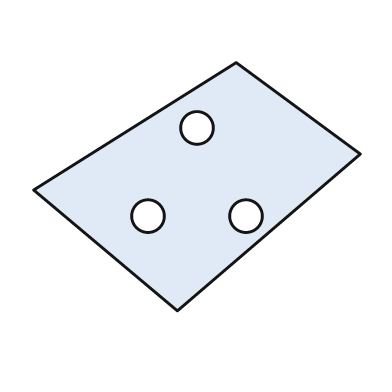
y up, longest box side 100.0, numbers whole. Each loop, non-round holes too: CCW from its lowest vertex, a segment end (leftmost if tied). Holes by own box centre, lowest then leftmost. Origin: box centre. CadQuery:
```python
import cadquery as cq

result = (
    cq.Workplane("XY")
    .moveTo(-6.0, -38.0)
    .lineTo(50.0, 10.0)
    .lineTo(12.0, 38.0)
    .lineTo(-50.0, -1.0)
    .close()
    .moveTo(-15.0, -9.0)
    .circle(5.0)
    .moveTo(15.0, -9.0)
    .circle(5.0)
    .moveTo(0.0, 18.0)
    .circle(5.0)
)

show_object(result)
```